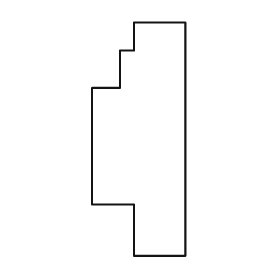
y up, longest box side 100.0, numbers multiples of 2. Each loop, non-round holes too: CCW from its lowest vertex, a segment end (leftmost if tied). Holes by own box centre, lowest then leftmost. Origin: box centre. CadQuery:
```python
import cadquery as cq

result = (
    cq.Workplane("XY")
    .moveTo(-2.0, -50.0)
    .lineTo(20.0, -50.0)
    .lineTo(20.0, 50.0)
    .lineTo(-2.0, 50.0)
    .lineTo(-2.0, 38.0)
    .lineTo(-8.0, 38.0)
    .lineTo(-8.0, 22.0)
    .lineTo(-20.0, 22.0)
    .lineTo(-20.0, -28.0)
    .lineTo(-2.0, -28.0)
    .close()
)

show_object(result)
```